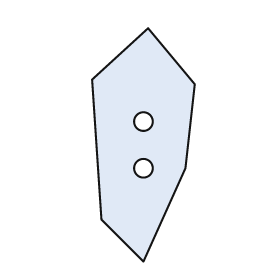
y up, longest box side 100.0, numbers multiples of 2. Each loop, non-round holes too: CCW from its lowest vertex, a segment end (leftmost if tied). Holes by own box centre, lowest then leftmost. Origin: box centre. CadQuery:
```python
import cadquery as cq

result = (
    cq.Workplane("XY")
    .moveTo(0.0, -50.0)
    .lineTo(18.0, -10.0)
    .lineTo(22.0, 26.0)
    .lineTo(2.0, 50.0)
    .lineTo(-22.0, 28.0)
    .lineTo(-18.0, -32.0)
    .close()
    .moveTo(0.0, -10.0)
    .circle(4.0)
    .moveTo(0.0, 10.0)
    .circle(4.0)
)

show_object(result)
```